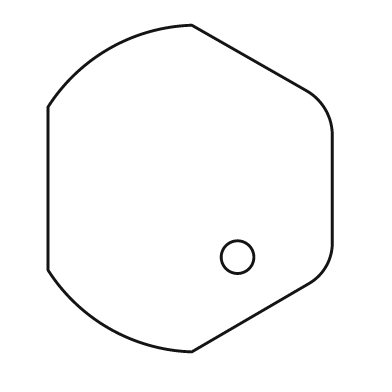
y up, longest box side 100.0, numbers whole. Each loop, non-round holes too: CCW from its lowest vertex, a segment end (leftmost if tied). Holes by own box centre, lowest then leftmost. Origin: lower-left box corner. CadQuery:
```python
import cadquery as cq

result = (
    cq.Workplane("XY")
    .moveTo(44.0, 0.0)
    .lineTo(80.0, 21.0)
    .threePointArc((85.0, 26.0), (87.0, 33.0))
    .lineTo(87.0, 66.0)
    .threePointArc((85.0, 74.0), (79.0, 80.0))
    .lineTo(44.0, 100.0)
    .threePointArc((19.0, 93.0), (0.0, 75.0))
    .lineTo(0.0, 25.0)
    .threePointArc((19.0, 7.0), (44.0, 0.0))
    .close()
    .moveTo(58.0, 29.0)
    .circle(5.0)
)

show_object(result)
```